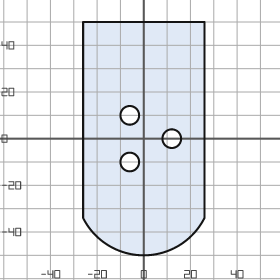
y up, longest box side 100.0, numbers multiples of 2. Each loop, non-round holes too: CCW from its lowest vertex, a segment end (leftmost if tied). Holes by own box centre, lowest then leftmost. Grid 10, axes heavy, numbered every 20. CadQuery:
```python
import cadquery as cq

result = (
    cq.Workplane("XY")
    .moveTo(-26.0, -34.0)
    .threePointArc((0.0, -50.0), (26.0, -34.0))
    .lineTo(26.0, 50.0)
    .lineTo(-26.0, 50.0)
    .close()
    .moveTo(-6.0, -10.0)
    .circle(4.0)
    .moveTo(12.0, 0.0)
    .circle(4.0)
    .moveTo(-6.0, 10.0)
    .circle(4.0)
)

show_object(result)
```